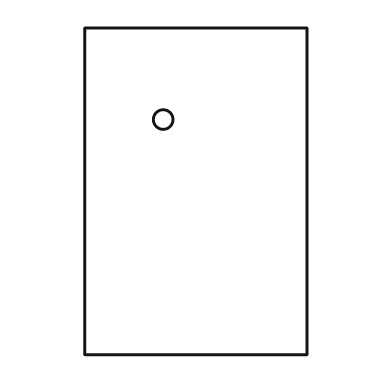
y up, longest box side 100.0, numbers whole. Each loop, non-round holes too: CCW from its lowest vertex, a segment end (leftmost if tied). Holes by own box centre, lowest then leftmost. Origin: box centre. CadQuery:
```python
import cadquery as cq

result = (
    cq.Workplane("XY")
    .moveTo(-34.0, -50.0)
    .lineTo(34.0, -50.0)
    .lineTo(34.0, 50.0)
    .lineTo(-34.0, 50.0)
    .close()
    .moveTo(-10.0, 22.0)
    .circle(3.0)
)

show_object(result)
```